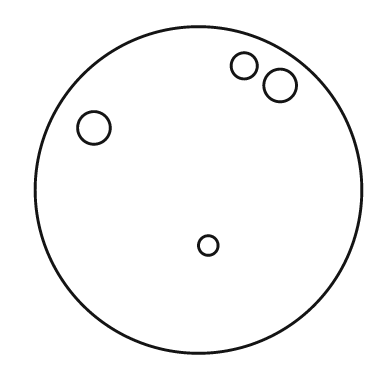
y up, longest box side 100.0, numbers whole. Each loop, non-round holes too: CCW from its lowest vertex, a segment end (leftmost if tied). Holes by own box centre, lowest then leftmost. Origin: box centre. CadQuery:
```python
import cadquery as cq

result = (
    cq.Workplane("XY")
    .moveTo(0.0, 0.0)
    .circle(50.0)
    .moveTo(3.0, -17.0)
    .circle(3.0)
    .moveTo(-32.0, 19.0)
    .circle(5.0)
    .moveTo(25.0, 32.0)
    .circle(5.0)
    .moveTo(14.0, 38.0)
    .circle(4.0)
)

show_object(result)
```